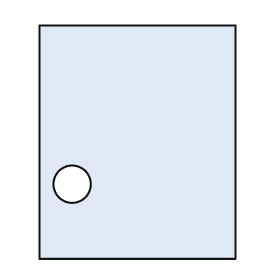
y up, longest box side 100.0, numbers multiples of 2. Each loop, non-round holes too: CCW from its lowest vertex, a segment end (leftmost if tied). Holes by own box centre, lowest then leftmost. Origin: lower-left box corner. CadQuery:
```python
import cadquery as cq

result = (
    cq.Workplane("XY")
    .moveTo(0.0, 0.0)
    .lineTo(84.0, 0.0)
    .lineTo(84.0, 100.0)
    .lineTo(0.0, 100.0)
    .close()
    .moveTo(14.0, 32.0)
    .circle(8.0)
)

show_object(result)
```